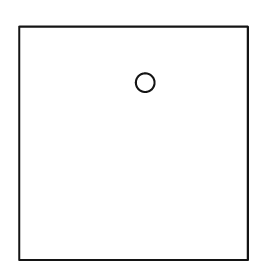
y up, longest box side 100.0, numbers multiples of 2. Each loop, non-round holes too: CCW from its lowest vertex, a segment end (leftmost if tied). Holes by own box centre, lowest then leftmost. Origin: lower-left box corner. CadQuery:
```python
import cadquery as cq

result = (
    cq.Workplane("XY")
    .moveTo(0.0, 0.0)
    .lineTo(98.0, 0.0)
    .lineTo(98.0, 100.0)
    .lineTo(0.0, 100.0)
    .close()
    .moveTo(54.0, 76.0)
    .circle(4.0)
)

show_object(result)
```